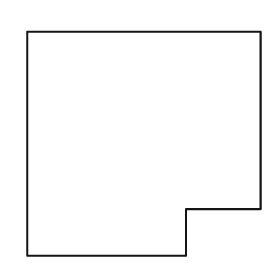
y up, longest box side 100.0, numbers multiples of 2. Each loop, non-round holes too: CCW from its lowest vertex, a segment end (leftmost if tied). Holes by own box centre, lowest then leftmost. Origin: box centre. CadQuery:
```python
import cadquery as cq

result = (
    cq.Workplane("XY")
    .moveTo(-50.0, -48.0)
    .lineTo(18.0, -48.0)
    .lineTo(18.0, -28.0)
    .lineTo(50.0, -28.0)
    .lineTo(50.0, 48.0)
    .lineTo(-50.0, 48.0)
    .close()
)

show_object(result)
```